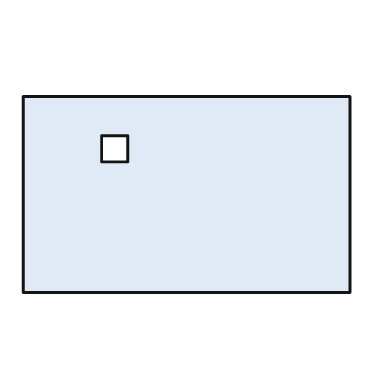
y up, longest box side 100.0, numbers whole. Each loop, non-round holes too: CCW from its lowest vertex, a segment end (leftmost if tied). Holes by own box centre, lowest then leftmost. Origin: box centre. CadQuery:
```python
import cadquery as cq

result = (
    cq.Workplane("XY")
    .moveTo(-50.0, -30.0)
    .lineTo(50.0, -30.0)
    .lineTo(50.0, 30.0)
    .lineTo(-50.0, 30.0)
    .close()
    .moveTo(-26.0, 10.0)
    .lineTo(-18.0, 10.0)
    .lineTo(-18.0, 18.0)
    .lineTo(-26.0, 18.0)
    .close()
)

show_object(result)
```